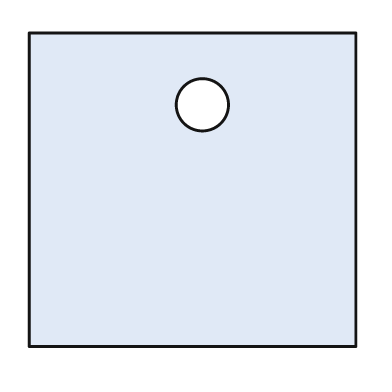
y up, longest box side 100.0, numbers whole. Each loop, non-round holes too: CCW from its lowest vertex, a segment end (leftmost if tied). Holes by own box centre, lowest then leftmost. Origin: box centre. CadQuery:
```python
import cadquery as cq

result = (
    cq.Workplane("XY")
    .moveTo(-50.0, -48.0)
    .lineTo(50.0, -48.0)
    .lineTo(50.0, 48.0)
    .lineTo(-50.0, 48.0)
    .close()
    .moveTo(3.0, 26.0)
    .circle(8.0)
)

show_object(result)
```